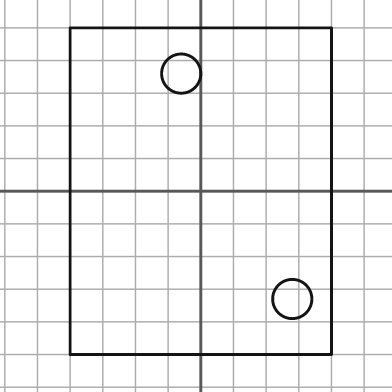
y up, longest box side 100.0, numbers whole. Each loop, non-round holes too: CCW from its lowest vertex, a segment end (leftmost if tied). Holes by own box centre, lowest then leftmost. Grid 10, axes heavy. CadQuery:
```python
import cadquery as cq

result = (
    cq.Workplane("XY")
    .moveTo(-40.0, -50.0)
    .lineTo(40.0, -50.0)
    .lineTo(40.0, 50.0)
    .lineTo(-40.0, 50.0)
    .close()
    .moveTo(28.0, -33.0)
    .circle(6.0)
    .moveTo(-6.0, 36.0)
    .circle(6.0)
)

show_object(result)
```